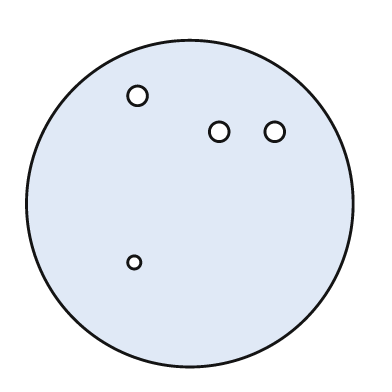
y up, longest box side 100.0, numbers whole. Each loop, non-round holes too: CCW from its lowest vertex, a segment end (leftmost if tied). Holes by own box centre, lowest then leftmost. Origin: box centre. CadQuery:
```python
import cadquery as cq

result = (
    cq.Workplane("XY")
    .moveTo(0.0, 0.0)
    .circle(50.0)
    .moveTo(-17.0, -18.0)
    .circle(2.0)
    .moveTo(9.0, 22.0)
    .circle(3.0)
    .moveTo(26.0, 22.0)
    .circle(3.0)
    .moveTo(-16.0, 33.0)
    .circle(3.0)
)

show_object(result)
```